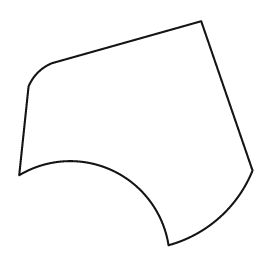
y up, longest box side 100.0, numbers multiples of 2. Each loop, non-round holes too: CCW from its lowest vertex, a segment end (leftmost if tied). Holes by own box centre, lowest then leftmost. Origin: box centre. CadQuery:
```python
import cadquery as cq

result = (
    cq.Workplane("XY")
    .moveTo(14.0, -48.0)
    .threePointArc((36.0, -36.0), (50.0, -16.0))
    .lineTo(28.0, 48.0)
    .lineTo(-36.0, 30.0)
    .threePointArc((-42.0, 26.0), (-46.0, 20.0))
    .lineTo(-50.0, -18.0)
    .threePointArc((-10.0, -16.0), (14.0, -48.0))
    .close()
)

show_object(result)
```